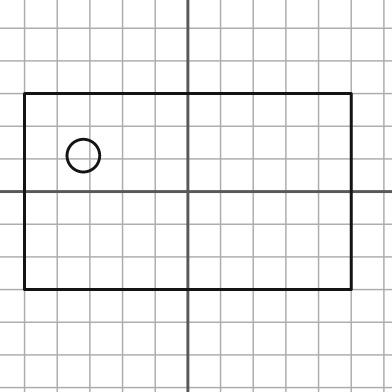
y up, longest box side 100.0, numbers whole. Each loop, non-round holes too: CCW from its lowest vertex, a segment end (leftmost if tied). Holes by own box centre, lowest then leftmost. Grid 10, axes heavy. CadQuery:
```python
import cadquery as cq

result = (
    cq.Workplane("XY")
    .moveTo(-50.0, -30.0)
    .lineTo(50.0, -30.0)
    .lineTo(50.0, 30.0)
    .lineTo(-50.0, 30.0)
    .close()
    .moveTo(-32.0, 11.0)
    .circle(5.0)
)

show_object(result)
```